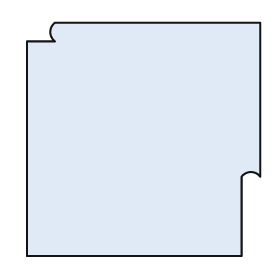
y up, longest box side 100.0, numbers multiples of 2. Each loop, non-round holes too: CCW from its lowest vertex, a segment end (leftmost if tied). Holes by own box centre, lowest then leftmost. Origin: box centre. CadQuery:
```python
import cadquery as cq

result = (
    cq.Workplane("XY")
    .moveTo(-50.0, -50.0)
    .lineTo(42.0, -50.0)
    .lineTo(42.0, -16.0)
    .threePointArc((46.0, -14.0), (50.0, -16.0))
    .lineTo(50.0, 50.0)
    .lineTo(-38.0, 50.0)
    .threePointArc((-40.0, 46.0), (-38.0, 42.0))
    .lineTo(-50.0, 42.0)
    .close()
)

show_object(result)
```